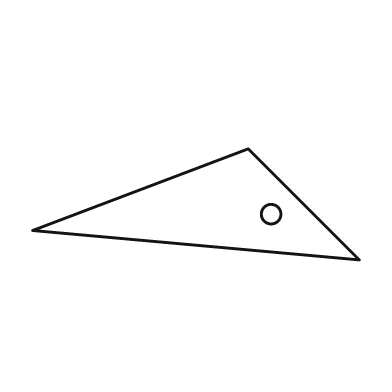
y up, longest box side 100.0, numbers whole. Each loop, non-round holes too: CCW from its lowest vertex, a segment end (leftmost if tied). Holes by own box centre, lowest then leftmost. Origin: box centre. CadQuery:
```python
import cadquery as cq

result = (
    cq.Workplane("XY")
    .moveTo(50.0, -17.0)
    .lineTo(16.0, 17.0)
    .lineTo(-50.0, -8.0)
    .close()
    .moveTo(23.0, -3.0)
    .circle(3.0)
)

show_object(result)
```